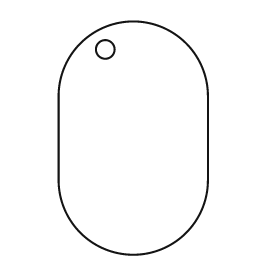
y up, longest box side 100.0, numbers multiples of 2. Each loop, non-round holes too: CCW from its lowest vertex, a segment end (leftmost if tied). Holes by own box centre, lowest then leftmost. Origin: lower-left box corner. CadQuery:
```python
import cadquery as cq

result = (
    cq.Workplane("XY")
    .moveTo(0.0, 32.0)
    .threePointArc((32.0, 0.0), (64.0, 32.0))
    .lineTo(64.0, 68.0)
    .threePointArc((32.0, 100.0), (0.0, 68.0))
    .close()
    .moveTo(20.0, 88.0)
    .circle(4.0)
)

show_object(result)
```